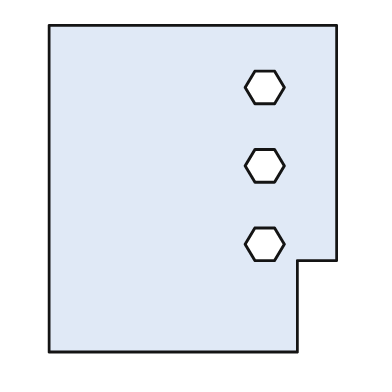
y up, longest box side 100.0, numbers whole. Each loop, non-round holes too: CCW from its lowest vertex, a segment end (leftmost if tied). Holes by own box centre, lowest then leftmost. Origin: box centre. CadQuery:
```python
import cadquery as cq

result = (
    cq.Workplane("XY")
    .moveTo(-44.0, -50.0)
    .lineTo(32.0, -50.0)
    .lineTo(32.0, -22.0)
    .lineTo(44.0, -22.0)
    .lineTo(44.0, 50.0)
    .lineTo(-44.0, 50.0)
    .close()
    .moveTo(19.0, -22.0)
    .lineTo(25.0, -22.0)
    .lineTo(28.0, -17.0)
    .lineTo(25.0, -12.0)
    .lineTo(19.0, -12.0)
    .lineTo(16.0, -17.0)
    .close()
    .moveTo(19.0, 2.0)
    .lineTo(25.0, 2.0)
    .lineTo(28.0, 7.0)
    .lineTo(25.0, 12.0)
    .lineTo(19.0, 12.0)
    .lineTo(16.0, 7.0)
    .close()
    .moveTo(19.0, 26.0)
    .lineTo(25.0, 26.0)
    .lineTo(28.0, 31.0)
    .lineTo(25.0, 36.0)
    .lineTo(19.0, 36.0)
    .lineTo(16.0, 31.0)
    .close()
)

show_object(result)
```